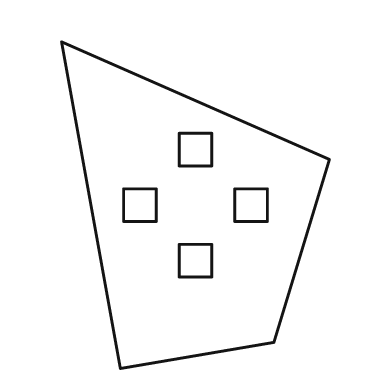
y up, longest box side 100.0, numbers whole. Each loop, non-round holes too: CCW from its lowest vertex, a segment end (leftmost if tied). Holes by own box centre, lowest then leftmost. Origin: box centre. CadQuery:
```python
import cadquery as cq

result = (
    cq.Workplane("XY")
    .moveTo(-23.0, -50.0)
    .lineTo(24.0, -42.0)
    .lineTo(41.0, 14.0)
    .lineTo(-41.0, 50.0)
    .close()
    .moveTo(-5.0, -22.0)
    .lineTo(5.0, -22.0)
    .lineTo(5.0, -12.0)
    .lineTo(-5.0, -12.0)
    .close()
    .moveTo(-22.0, -5.0)
    .lineTo(-12.0, -5.0)
    .lineTo(-12.0, 5.0)
    .lineTo(-22.0, 5.0)
    .close()
    .moveTo(12.0, -5.0)
    .lineTo(22.0, -5.0)
    .lineTo(22.0, 5.0)
    .lineTo(12.0, 5.0)
    .close()
    .moveTo(-5.0, 12.0)
    .lineTo(5.0, 12.0)
    .lineTo(5.0, 22.0)
    .lineTo(-5.0, 22.0)
    .close()
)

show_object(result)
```